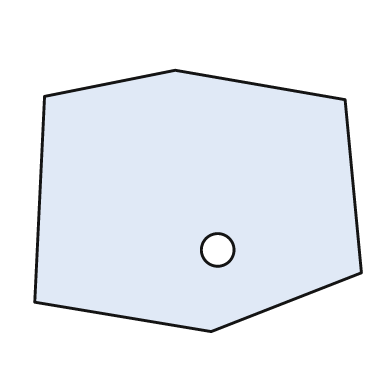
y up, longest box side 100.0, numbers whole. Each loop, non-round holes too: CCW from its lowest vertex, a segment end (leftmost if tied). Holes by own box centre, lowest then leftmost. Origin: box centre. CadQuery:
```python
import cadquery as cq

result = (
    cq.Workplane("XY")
    .moveTo(4.0, -40.0)
    .lineTo(50.0, -22.0)
    .lineTo(45.0, 31.0)
    .lineTo(-7.0, 40.0)
    .lineTo(-47.0, 32.0)
    .lineTo(-50.0, -31.0)
    .close()
    .moveTo(6.0, -15.0)
    .circle(5.0)
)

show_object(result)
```